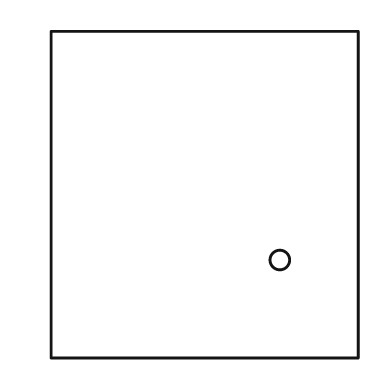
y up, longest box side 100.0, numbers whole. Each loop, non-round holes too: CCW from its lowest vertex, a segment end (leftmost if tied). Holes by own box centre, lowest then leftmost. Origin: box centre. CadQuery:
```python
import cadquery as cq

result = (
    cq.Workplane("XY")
    .moveTo(-47.0, -50.0)
    .lineTo(47.0, -50.0)
    .lineTo(47.0, 50.0)
    .lineTo(-47.0, 50.0)
    .close()
    .moveTo(23.0, -20.0)
    .circle(3.0)
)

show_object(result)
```